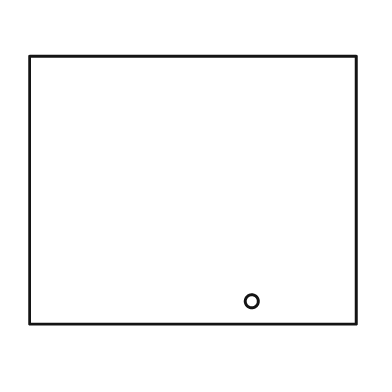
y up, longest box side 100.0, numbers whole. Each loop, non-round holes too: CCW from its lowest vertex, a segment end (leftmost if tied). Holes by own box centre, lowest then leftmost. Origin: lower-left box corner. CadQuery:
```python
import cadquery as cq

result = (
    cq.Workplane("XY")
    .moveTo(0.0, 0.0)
    .lineTo(100.0, 0.0)
    .lineTo(100.0, 82.0)
    .lineTo(0.0, 82.0)
    .close()
    .moveTo(68.0, 7.0)
    .circle(2.0)
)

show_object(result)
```